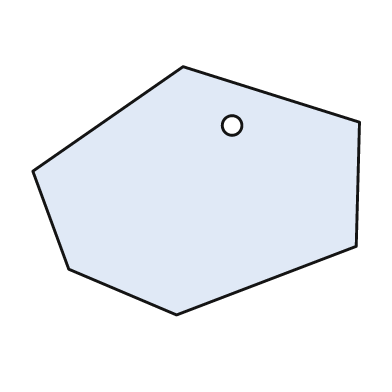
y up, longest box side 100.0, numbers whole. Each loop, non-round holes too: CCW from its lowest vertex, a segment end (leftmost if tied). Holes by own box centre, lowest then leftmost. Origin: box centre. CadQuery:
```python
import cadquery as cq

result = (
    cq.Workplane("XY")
    .moveTo(-6.0, -38.0)
    .lineTo(49.0, -17.0)
    .lineTo(50.0, 21.0)
    .lineTo(-4.0, 38.0)
    .lineTo(-50.0, 6.0)
    .lineTo(-39.0, -24.0)
    .close()
    .moveTo(11.0, 20.0)
    .circle(3.0)
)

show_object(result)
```